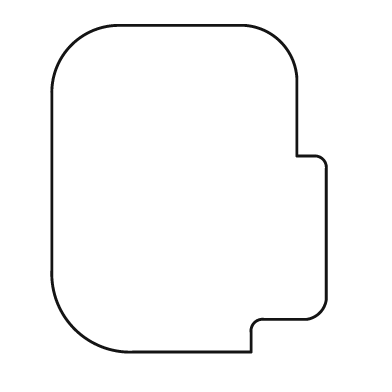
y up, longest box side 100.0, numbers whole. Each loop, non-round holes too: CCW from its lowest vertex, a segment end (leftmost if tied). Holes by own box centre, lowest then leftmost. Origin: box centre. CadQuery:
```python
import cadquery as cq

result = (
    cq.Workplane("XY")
    .moveTo(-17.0, -50.0)
    .lineTo(19.0, -50.0)
    .lineTo(19.0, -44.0)
    .threePointArc((20.0, -41.0), (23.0, -40.0))
    .lineTo(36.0, -40.0)
    .threePointArc((40.0, -38.0), (42.0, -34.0))
    .lineTo(42.0, 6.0)
    .threePointArc((41.0, 9.0), (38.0, 10.0))
    .lineTo(33.0, 10.0)
    .lineTo(33.0, 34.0)
    .threePointArc((28.0, 45.0), (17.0, 50.0))
    .lineTo(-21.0, 50.0)
    .threePointArc((-36.0, 44.0), (-42.0, 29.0))
    .lineTo(-42.0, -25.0)
    .threePointArc((-35.0, -43.0), (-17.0, -50.0))
    .close()
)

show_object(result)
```